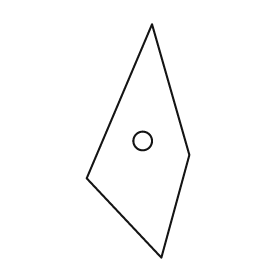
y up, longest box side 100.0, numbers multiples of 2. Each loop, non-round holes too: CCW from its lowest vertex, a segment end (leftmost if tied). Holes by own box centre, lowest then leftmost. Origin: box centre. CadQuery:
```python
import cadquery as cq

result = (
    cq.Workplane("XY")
    .moveTo(10.0, -50.0)
    .lineTo(22.0, -6.0)
    .lineTo(6.0, 50.0)
    .lineTo(-22.0, -16.0)
    .close()
    .moveTo(2.0, 0.0)
    .circle(4.0)
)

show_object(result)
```